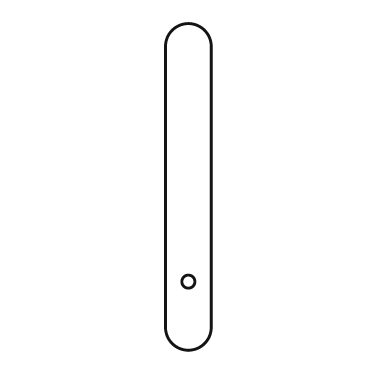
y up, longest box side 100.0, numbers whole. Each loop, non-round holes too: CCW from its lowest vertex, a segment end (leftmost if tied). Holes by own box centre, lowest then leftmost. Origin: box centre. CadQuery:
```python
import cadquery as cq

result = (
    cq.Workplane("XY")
    .moveTo(-7.0, -43.0)
    .threePointArc((0.0, -50.0), (7.0, -43.0))
    .lineTo(7.0, 43.0)
    .threePointArc((0.0, 50.0), (-7.0, 43.0))
    .close()
    .moveTo(0.0, -29.0)
    .circle(2.0)
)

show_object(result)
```